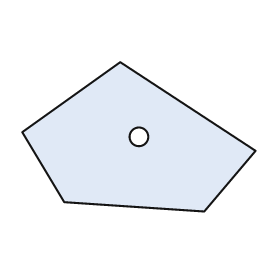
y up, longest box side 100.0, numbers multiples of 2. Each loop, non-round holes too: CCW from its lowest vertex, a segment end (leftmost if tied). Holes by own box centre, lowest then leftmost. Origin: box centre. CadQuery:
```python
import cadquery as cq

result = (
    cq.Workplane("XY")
    .moveTo(28.0, -32.0)
    .lineTo(50.0, -6.0)
    .lineTo(-8.0, 32.0)
    .lineTo(-50.0, 2.0)
    .lineTo(-32.0, -28.0)
    .close()
    .moveTo(0.0, 0.0)
    .circle(4.0)
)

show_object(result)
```